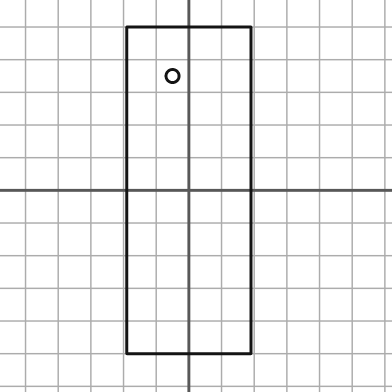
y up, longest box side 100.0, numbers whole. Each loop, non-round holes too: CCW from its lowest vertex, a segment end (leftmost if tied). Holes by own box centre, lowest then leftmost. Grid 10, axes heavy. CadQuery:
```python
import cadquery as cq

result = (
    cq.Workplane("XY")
    .moveTo(-19.0, -50.0)
    .lineTo(19.0, -50.0)
    .lineTo(19.0, 50.0)
    .lineTo(-19.0, 50.0)
    .close()
    .moveTo(-5.0, 35.0)
    .circle(2.0)
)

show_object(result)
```